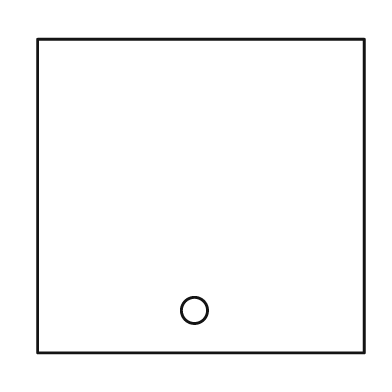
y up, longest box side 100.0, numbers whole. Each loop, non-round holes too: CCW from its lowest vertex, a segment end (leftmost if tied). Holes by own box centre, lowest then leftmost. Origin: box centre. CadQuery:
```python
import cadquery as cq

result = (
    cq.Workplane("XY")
    .moveTo(-50.0, -48.0)
    .lineTo(50.0, -48.0)
    .lineTo(50.0, 48.0)
    .lineTo(-50.0, 48.0)
    .close()
    .moveTo(-2.0, -35.0)
    .circle(4.0)
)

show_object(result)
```